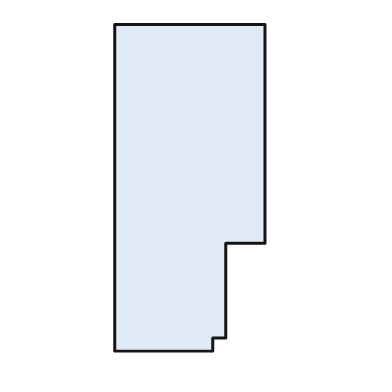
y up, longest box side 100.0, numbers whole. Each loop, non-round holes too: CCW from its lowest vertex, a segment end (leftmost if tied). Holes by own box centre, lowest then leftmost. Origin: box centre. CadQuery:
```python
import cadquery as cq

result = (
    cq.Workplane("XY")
    .moveTo(-23.0, -50.0)
    .lineTo(7.0, -50.0)
    .lineTo(7.0, -46.0)
    .lineTo(11.0, -46.0)
    .lineTo(11.0, -17.0)
    .lineTo(23.0, -17.0)
    .lineTo(23.0, 50.0)
    .lineTo(-23.0, 50.0)
    .close()
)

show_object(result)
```